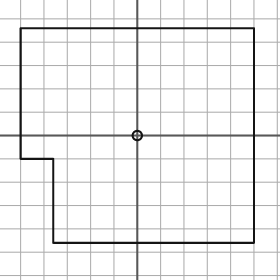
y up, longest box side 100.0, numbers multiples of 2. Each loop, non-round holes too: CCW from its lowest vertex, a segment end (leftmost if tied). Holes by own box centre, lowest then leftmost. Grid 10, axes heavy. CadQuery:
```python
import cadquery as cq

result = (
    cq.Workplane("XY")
    .moveTo(-36.0, -46.0)
    .lineTo(50.0, -46.0)
    .lineTo(50.0, 46.0)
    .lineTo(-50.0, 46.0)
    .lineTo(-50.0, -10.0)
    .lineTo(-36.0, -10.0)
    .close()
    .moveTo(0.0, 0.0)
    .circle(2.0)
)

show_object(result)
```